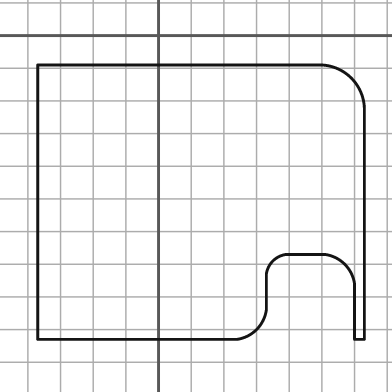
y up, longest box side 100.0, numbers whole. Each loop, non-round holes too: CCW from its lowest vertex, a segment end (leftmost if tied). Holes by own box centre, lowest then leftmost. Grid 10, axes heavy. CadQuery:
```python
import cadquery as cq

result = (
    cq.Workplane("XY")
    .moveTo(-37.0, -93.0)
    .lineTo(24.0, -93.0)
    .threePointArc((30.0, -90.0), (33.0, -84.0))
    .lineTo(33.0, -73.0)
    .threePointArc((35.0, -69.0), (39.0, -67.0))
    .lineTo(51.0, -67.0)
    .threePointArc((57.0, -70.0), (60.0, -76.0))
    .lineTo(60.0, -93.0)
    .lineTo(63.0, -93.0)
    .lineTo(63.0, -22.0)
    .threePointArc((59.0, -13.0), (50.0, -9.0))
    .lineTo(-37.0, -9.0)
    .close()
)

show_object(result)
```